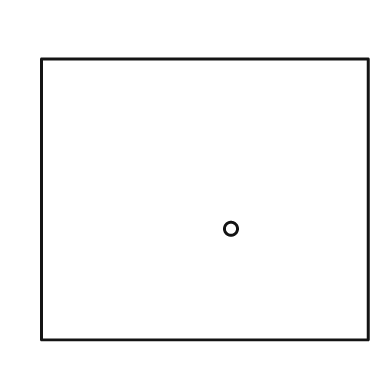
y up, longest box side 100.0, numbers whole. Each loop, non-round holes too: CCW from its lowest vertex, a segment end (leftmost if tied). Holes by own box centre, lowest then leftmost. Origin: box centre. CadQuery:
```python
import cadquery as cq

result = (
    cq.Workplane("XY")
    .moveTo(-50.0, -43.0)
    .lineTo(50.0, -43.0)
    .lineTo(50.0, 43.0)
    .lineTo(-50.0, 43.0)
    .close()
    .moveTo(8.0, -9.0)
    .circle(2.0)
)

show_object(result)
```